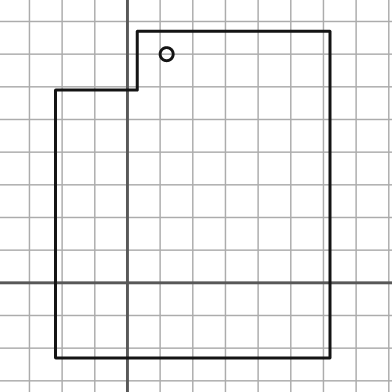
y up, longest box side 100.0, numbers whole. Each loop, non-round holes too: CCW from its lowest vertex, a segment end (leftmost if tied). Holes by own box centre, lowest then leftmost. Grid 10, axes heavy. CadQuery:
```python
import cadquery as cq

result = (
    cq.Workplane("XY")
    .moveTo(-22.0, -23.0)
    .lineTo(62.0, -23.0)
    .lineTo(62.0, 77.0)
    .lineTo(3.0, 77.0)
    .lineTo(3.0, 59.0)
    .lineTo(-22.0, 59.0)
    .close()
    .moveTo(12.0, 70.0)
    .circle(2.0)
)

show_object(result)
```